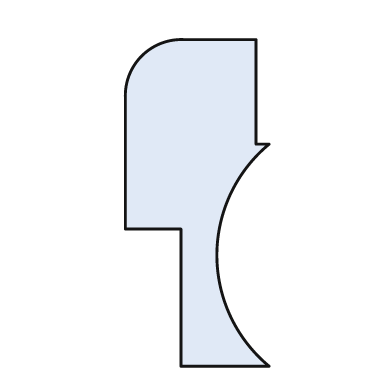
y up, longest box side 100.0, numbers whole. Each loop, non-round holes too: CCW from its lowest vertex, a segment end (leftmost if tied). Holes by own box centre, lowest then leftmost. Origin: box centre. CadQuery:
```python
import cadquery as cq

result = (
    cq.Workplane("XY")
    .moveTo(-5.0, -50.0)
    .lineTo(22.0, -50.0)
    .threePointArc((6.0, -16.0), (22.0, 18.0))
    .lineTo(18.0, 18.0)
    .lineTo(18.0, 50.0)
    .lineTo(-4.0, 50.0)
    .threePointArc((-17.0, 45.0), (-22.0, 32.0))
    .lineTo(-22.0, -8.0)
    .lineTo(-5.0, -8.0)
    .close()
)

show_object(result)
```